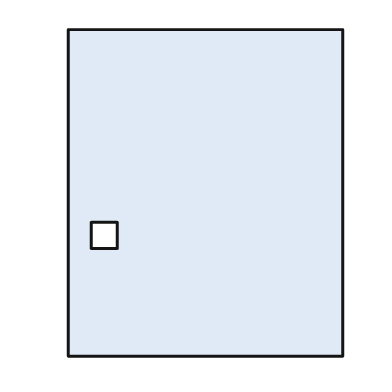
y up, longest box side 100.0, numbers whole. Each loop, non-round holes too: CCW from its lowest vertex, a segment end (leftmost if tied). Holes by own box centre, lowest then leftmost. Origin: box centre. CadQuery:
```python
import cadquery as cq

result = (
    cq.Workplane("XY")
    .moveTo(-42.0, -50.0)
    .lineTo(42.0, -50.0)
    .lineTo(42.0, 50.0)
    .lineTo(-42.0, 50.0)
    .close()
    .moveTo(-35.0, -17.0)
    .lineTo(-27.0, -17.0)
    .lineTo(-27.0, -9.0)
    .lineTo(-35.0, -9.0)
    .close()
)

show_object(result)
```